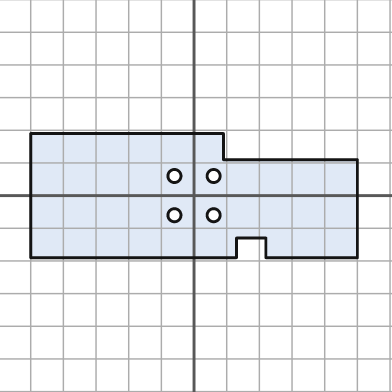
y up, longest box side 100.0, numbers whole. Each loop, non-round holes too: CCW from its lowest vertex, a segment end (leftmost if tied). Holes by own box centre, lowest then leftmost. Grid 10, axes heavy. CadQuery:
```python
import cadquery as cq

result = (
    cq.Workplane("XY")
    .moveTo(-50.0, -19.0)
    .lineTo(13.0, -19.0)
    .lineTo(13.0, -13.0)
    .lineTo(22.0, -13.0)
    .lineTo(22.0, -19.0)
    .lineTo(50.0, -19.0)
    .lineTo(50.0, 11.0)
    .lineTo(9.0, 11.0)
    .lineTo(9.0, 19.0)
    .lineTo(-50.0, 19.0)
    .close()
    .moveTo(-6.0, -6.0)
    .circle(2.0)
    .moveTo(6.0, -6.0)
    .circle(2.0)
    .moveTo(-6.0, 6.0)
    .circle(2.0)
    .moveTo(6.0, 6.0)
    .circle(2.0)
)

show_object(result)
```